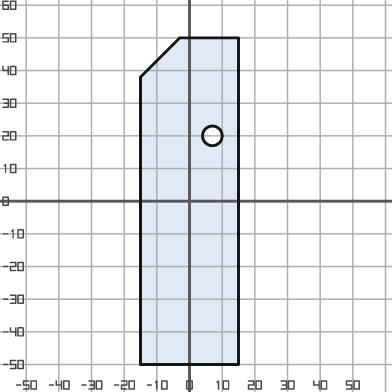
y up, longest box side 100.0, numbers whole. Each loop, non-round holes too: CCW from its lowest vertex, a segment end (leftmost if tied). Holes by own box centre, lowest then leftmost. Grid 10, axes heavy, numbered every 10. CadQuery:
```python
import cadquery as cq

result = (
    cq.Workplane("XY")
    .moveTo(-15.0, -50.0)
    .lineTo(15.0, -50.0)
    .lineTo(15.0, 50.0)
    .lineTo(-3.0, 50.0)
    .lineTo(-15.0, 38.0)
    .close()
    .moveTo(7.0, 20.0)
    .circle(3.0)
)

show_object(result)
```